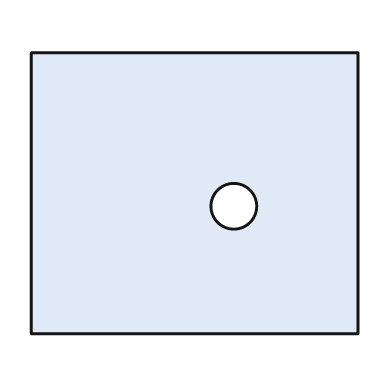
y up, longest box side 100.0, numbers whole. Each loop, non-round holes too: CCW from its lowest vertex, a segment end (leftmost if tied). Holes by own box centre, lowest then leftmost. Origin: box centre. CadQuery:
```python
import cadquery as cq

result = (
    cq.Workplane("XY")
    .moveTo(-50.0, -43.0)
    .lineTo(50.0, -43.0)
    .lineTo(50.0, 43.0)
    .lineTo(-50.0, 43.0)
    .close()
    .moveTo(12.0, -4.0)
    .circle(7.0)
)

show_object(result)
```